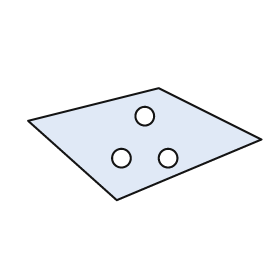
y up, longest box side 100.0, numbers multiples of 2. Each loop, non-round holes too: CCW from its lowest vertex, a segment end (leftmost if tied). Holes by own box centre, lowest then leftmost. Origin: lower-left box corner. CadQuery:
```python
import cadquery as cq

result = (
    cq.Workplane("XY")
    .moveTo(38.0, 0.0)
    .lineTo(100.0, 26.0)
    .lineTo(56.0, 48.0)
    .lineTo(0.0, 34.0)
    .close()
    .moveTo(40.0, 18.0)
    .circle(4.0)
    .moveTo(60.0, 18.0)
    .circle(4.0)
    .moveTo(50.0, 36.0)
    .circle(4.0)
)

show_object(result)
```